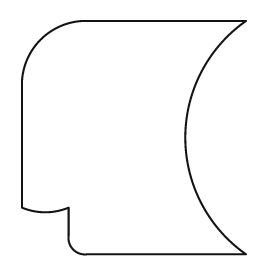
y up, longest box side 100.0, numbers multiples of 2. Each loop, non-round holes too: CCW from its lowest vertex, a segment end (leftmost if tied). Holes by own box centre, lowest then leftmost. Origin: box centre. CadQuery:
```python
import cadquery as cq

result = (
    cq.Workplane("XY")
    .moveTo(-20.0, -50.0)
    .lineTo(48.0, -50.0)
    .threePointArc((22.0, 0.0), (48.0, 50.0))
    .lineTo(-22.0, 50.0)
    .threePointArc((-40.0, 42.0), (-48.0, 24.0))
    .lineTo(-48.0, -30.0)
    .threePointArc((-38.0, -32.0), (-28.0, -30.0))
    .lineTo(-28.0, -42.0)
    .threePointArc((-26.0, -48.0), (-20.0, -50.0))
    .close()
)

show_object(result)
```